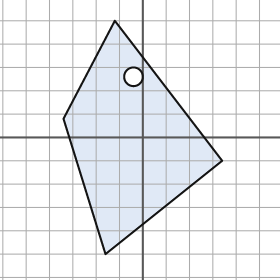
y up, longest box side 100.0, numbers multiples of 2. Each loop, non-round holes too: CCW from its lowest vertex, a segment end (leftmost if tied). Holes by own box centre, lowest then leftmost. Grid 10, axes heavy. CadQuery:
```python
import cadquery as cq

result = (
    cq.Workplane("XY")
    .moveTo(-16.0, -50.0)
    .lineTo(34.0, -10.0)
    .lineTo(-12.0, 50.0)
    .lineTo(-34.0, 8.0)
    .close()
    .moveTo(-4.0, 26.0)
    .circle(4.0)
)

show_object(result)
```